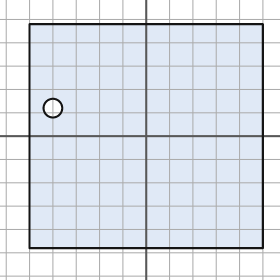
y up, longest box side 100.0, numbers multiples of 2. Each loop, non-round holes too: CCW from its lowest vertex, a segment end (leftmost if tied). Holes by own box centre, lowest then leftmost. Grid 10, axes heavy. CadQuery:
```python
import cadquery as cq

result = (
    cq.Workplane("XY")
    .moveTo(-50.0, -48.0)
    .lineTo(50.0, -48.0)
    .lineTo(50.0, 48.0)
    .lineTo(-50.0, 48.0)
    .close()
    .moveTo(-40.0, 12.0)
    .circle(4.0)
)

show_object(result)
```